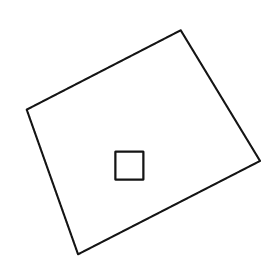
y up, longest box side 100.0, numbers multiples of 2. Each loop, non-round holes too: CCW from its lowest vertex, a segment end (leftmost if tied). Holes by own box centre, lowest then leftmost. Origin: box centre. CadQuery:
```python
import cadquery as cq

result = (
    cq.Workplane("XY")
    .moveTo(-28.0, -48.0)
    .lineTo(50.0, -8.0)
    .lineTo(16.0, 48.0)
    .lineTo(-50.0, 14.0)
    .close()
    .moveTo(-12.0, -16.0)
    .lineTo(0.0, -16.0)
    .lineTo(0.0, -4.0)
    .lineTo(-12.0, -4.0)
    .close()
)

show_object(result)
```